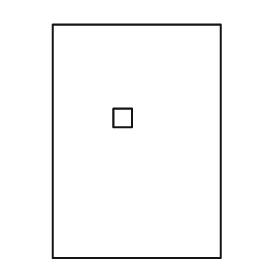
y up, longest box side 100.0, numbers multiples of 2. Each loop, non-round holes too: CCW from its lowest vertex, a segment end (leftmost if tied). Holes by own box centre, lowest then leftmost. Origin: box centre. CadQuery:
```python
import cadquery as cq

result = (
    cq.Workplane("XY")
    .moveTo(-36.0, -50.0)
    .lineTo(36.0, -50.0)
    .lineTo(36.0, 50.0)
    .lineTo(-36.0, 50.0)
    .close()
    .moveTo(-10.0, 6.0)
    .lineTo(-2.0, 6.0)
    .lineTo(-2.0, 14.0)
    .lineTo(-10.0, 14.0)
    .close()
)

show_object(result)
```